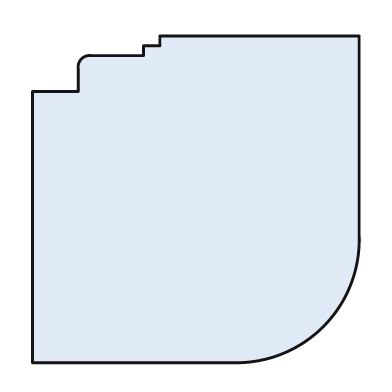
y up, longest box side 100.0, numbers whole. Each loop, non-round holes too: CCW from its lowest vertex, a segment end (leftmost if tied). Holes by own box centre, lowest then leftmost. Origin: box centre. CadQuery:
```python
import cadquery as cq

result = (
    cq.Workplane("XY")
    .moveTo(-50.0, -50.0)
    .lineTo(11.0, -50.0)
    .threePointArc((39.0, -39.0), (50.0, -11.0))
    .lineTo(50.0, 50.0)
    .lineTo(-11.0, 50.0)
    .lineTo(-11.0, 47.0)
    .lineTo(-16.0, 47.0)
    .lineTo(-16.0, 44.0)
    .lineTo(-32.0, 44.0)
    .threePointArc((-35.0, 43.0), (-36.0, 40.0))
    .lineTo(-36.0, 33.0)
    .lineTo(-50.0, 33.0)
    .close()
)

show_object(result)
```